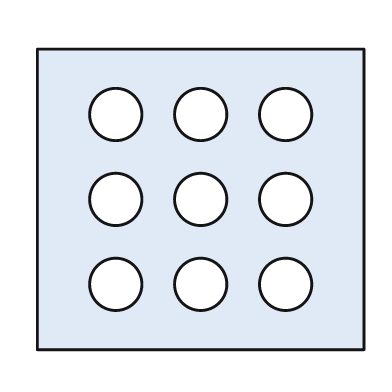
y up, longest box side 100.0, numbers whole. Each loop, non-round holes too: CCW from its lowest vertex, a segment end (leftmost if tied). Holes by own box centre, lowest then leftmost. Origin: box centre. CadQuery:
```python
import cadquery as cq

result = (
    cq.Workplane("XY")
    .moveTo(-50.0, -46.0)
    .lineTo(50.0, -46.0)
    .lineTo(50.0, 46.0)
    .lineTo(-50.0, 46.0)
    .close()
    .moveTo(-26.0, -26.0)
    .circle(8.0)
    .moveTo(0.0, -26.0)
    .circle(8.0)
    .moveTo(26.0, -26.0)
    .circle(8.0)
    .moveTo(-26.0, 0.0)
    .circle(8.0)
    .moveTo(0.0, 0.0)
    .circle(8.0)
    .moveTo(26.0, 0.0)
    .circle(8.0)
    .moveTo(-26.0, 26.0)
    .circle(8.0)
    .moveTo(0.0, 26.0)
    .circle(8.0)
    .moveTo(26.0, 26.0)
    .circle(8.0)
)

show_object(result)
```